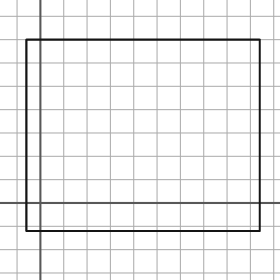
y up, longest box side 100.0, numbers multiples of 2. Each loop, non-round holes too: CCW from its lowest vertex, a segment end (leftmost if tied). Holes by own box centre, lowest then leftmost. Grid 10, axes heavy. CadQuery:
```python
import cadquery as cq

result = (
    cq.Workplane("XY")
    .moveTo(-6.0, -12.0)
    .lineTo(94.0, -12.0)
    .lineTo(94.0, 70.0)
    .lineTo(-6.0, 70.0)
    .close()
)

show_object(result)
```